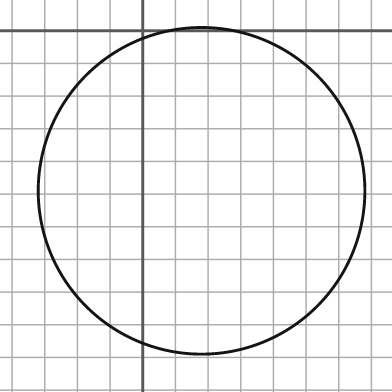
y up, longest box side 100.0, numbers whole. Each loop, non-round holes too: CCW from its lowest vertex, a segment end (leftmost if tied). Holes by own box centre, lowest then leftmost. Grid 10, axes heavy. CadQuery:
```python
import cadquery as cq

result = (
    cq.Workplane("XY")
    .moveTo(18.0, -49.0)
    .circle(50.0)
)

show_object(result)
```